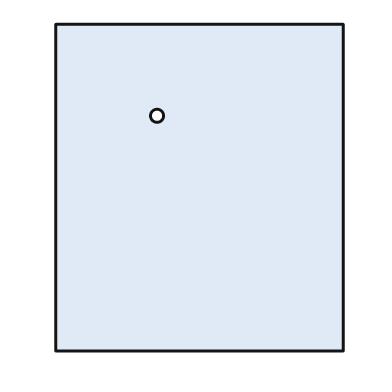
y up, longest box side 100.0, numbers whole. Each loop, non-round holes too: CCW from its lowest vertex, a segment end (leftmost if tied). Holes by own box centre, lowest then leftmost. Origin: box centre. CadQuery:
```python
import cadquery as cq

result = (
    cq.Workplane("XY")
    .moveTo(-44.0, -50.0)
    .lineTo(44.0, -50.0)
    .lineTo(44.0, 50.0)
    .lineTo(-44.0, 50.0)
    .close()
    .moveTo(-13.0, 22.0)
    .circle(2.0)
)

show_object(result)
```